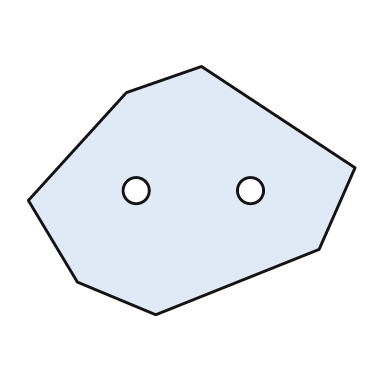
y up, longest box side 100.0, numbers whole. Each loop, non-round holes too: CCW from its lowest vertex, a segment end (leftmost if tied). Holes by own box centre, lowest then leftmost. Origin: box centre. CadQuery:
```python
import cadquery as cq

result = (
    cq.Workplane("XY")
    .moveTo(-11.0, -38.0)
    .lineTo(39.0, -18.0)
    .lineTo(50.0, 7.0)
    .lineTo(3.0, 38.0)
    .lineTo(-20.0, 30.0)
    .lineTo(-50.0, -3.0)
    .lineTo(-35.0, -28.0)
    .close()
    .moveTo(-17.0, 0.0)
    .circle(4.0)
    .moveTo(18.0, 0.0)
    .circle(4.0)
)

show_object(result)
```